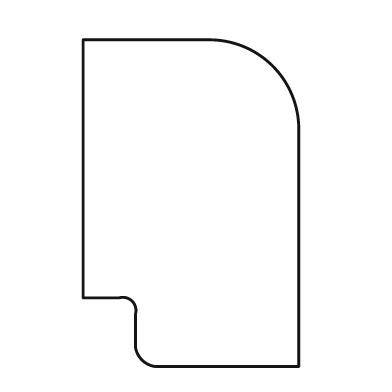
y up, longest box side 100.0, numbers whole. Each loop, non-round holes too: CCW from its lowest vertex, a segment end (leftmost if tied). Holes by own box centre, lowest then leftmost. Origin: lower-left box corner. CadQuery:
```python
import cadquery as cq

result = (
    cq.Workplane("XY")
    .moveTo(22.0, 0.0)
    .lineTo(66.0, 0.0)
    .lineTo(66.0, 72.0)
    .threePointArc((58.0, 92.0), (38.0, 100.0))
    .lineTo(0.0, 100.0)
    .lineTo(0.0, 21.0)
    .lineTo(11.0, 21.0)
    .threePointArc((15.0, 20.0), (16.0, 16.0))
    .lineTo(16.0, 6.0)
    .threePointArc((18.0, 2.0), (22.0, 0.0))
    .close()
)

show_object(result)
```